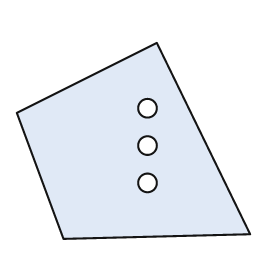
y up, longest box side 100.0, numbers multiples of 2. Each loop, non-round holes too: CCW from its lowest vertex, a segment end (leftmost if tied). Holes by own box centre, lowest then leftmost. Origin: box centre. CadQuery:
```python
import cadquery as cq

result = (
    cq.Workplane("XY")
    .moveTo(-30.0, -42.0)
    .lineTo(50.0, -40.0)
    .lineTo(10.0, 42.0)
    .lineTo(-50.0, 12.0)
    .close()
    .moveTo(6.0, -18.0)
    .circle(4.0)
    .moveTo(6.0, -2.0)
    .circle(4.0)
    .moveTo(6.0, 14.0)
    .circle(4.0)
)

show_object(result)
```